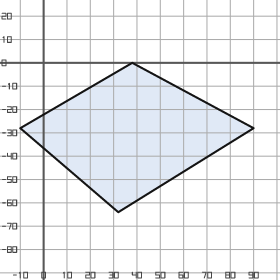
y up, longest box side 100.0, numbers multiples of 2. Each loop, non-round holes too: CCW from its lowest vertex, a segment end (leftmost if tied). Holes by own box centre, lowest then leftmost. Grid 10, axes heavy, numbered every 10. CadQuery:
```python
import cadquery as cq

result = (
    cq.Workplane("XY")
    .moveTo(32.0, -64.0)
    .lineTo(90.0, -28.0)
    .lineTo(38.0, 0.0)
    .lineTo(-10.0, -28.0)
    .close()
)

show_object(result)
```